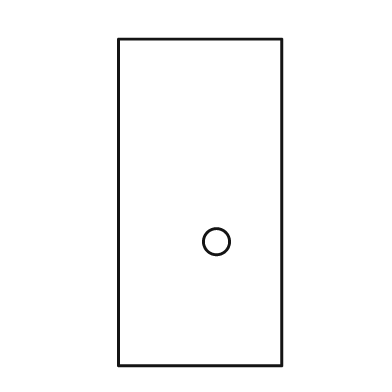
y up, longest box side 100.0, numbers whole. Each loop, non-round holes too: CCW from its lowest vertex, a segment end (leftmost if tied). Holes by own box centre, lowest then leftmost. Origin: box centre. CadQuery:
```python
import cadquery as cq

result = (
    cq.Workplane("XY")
    .moveTo(-25.0, -50.0)
    .lineTo(25.0, -50.0)
    .lineTo(25.0, 50.0)
    .lineTo(-25.0, 50.0)
    .close()
    .moveTo(5.0, -12.0)
    .circle(4.0)
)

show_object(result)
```